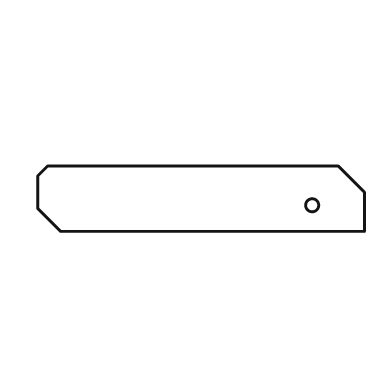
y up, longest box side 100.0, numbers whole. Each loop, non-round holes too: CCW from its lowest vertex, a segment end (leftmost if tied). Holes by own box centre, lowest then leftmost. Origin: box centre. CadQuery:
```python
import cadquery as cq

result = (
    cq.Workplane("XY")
    .moveTo(-43.0, -10.0)
    .lineTo(50.0, -10.0)
    .lineTo(50.0, 2.0)
    .lineTo(42.0, 10.0)
    .lineTo(-47.0, 10.0)
    .lineTo(-50.0, 7.0)
    .lineTo(-50.0, -3.0)
    .close()
    .moveTo(34.0, -2.0)
    .circle(2.0)
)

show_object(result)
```